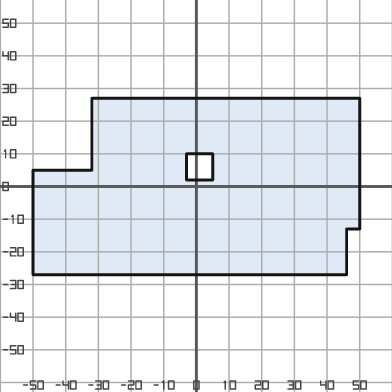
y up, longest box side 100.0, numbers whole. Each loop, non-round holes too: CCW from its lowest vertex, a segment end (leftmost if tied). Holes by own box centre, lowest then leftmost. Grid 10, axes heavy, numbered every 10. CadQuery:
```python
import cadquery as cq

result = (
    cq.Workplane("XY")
    .moveTo(-50.0, -27.0)
    .lineTo(46.0, -27.0)
    .lineTo(46.0, -13.0)
    .lineTo(50.0, -13.0)
    .lineTo(50.0, 27.0)
    .lineTo(-32.0, 27.0)
    .lineTo(-32.0, 5.0)
    .lineTo(-50.0, 5.0)
    .close()
    .moveTo(-3.0, 2.0)
    .lineTo(5.0, 2.0)
    .lineTo(5.0, 10.0)
    .lineTo(-3.0, 10.0)
    .close()
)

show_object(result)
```